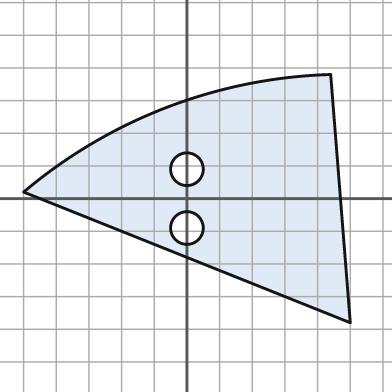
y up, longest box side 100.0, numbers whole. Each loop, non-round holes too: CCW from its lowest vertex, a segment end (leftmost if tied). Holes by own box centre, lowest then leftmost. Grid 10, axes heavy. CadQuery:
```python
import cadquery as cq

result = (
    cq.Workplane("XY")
    .moveTo(50.0, -38.0)
    .lineTo(44.0, 38.0)
    .threePointArc((-6.0, 28.0), (-50.0, 2.0))
    .close()
    .moveTo(0.0, -9.0)
    .circle(5.0)
    .moveTo(0.0, 9.0)
    .circle(5.0)
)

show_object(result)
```